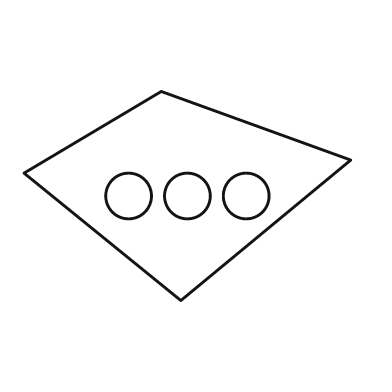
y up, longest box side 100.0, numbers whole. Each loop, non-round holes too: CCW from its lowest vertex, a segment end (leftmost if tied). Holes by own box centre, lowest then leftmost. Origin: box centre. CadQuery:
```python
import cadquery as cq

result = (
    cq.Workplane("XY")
    .moveTo(-2.0, -32.0)
    .lineTo(50.0, 11.0)
    .lineTo(-8.0, 32.0)
    .lineTo(-50.0, 7.0)
    .close()
    .moveTo(-18.0, 0.0)
    .circle(7.0)
    .moveTo(0.0, 0.0)
    .circle(7.0)
    .moveTo(18.0, 0.0)
    .circle(7.0)
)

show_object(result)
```